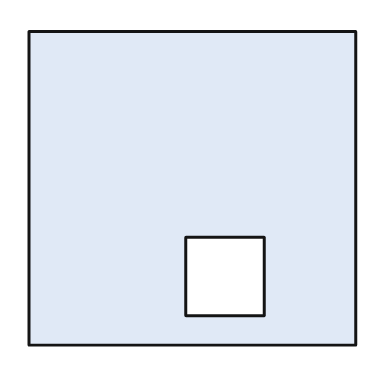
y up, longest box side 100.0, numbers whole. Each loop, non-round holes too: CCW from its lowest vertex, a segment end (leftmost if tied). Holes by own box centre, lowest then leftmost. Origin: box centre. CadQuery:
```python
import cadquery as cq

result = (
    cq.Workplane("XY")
    .moveTo(-50.0, -48.0)
    .lineTo(50.0, -48.0)
    .lineTo(50.0, 48.0)
    .lineTo(-50.0, 48.0)
    .close()
    .moveTo(-2.0, -39.0)
    .lineTo(22.0, -39.0)
    .lineTo(22.0, -15.0)
    .lineTo(-2.0, -15.0)
    .close()
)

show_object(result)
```